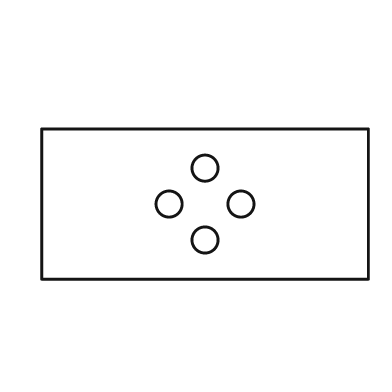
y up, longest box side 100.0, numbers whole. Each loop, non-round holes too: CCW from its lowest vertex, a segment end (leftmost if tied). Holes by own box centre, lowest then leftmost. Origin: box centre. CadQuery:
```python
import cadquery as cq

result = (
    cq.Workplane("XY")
    .moveTo(-50.0, -23.0)
    .lineTo(50.0, -23.0)
    .lineTo(50.0, 23.0)
    .lineTo(-50.0, 23.0)
    .close()
    .moveTo(0.0, -11.0)
    .circle(4.0)
    .moveTo(-11.0, 0.0)
    .circle(4.0)
    .moveTo(11.0, 0.0)
    .circle(4.0)
    .moveTo(0.0, 11.0)
    .circle(4.0)
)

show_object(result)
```